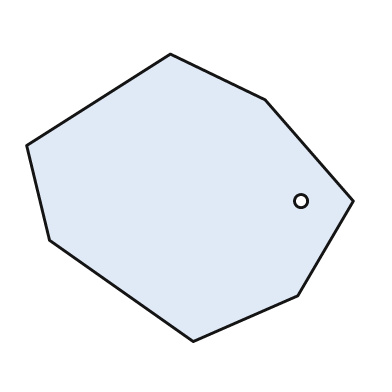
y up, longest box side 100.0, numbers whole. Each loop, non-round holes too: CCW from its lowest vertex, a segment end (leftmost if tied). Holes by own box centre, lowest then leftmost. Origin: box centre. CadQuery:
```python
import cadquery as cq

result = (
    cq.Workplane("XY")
    .moveTo(1.0, -44.0)
    .lineTo(33.0, -30.0)
    .lineTo(50.0, -1.0)
    .lineTo(23.0, 30.0)
    .lineTo(-6.0, 44.0)
    .lineTo(-50.0, 16.0)
    .lineTo(-43.0, -13.0)
    .close()
    .moveTo(34.0, -1.0)
    .circle(2.0)
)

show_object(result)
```